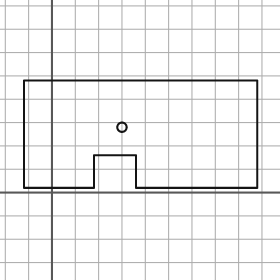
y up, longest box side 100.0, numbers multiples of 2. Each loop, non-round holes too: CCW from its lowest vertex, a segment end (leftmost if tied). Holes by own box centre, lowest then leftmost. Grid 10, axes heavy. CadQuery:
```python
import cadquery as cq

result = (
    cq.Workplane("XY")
    .moveTo(-12.0, 2.0)
    .lineTo(18.0, 2.0)
    .lineTo(18.0, 16.0)
    .lineTo(36.0, 16.0)
    .lineTo(36.0, 2.0)
    .lineTo(88.0, 2.0)
    .lineTo(88.0, 48.0)
    .lineTo(-12.0, 48.0)
    .close()
    .moveTo(30.0, 28.0)
    .circle(2.0)
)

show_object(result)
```